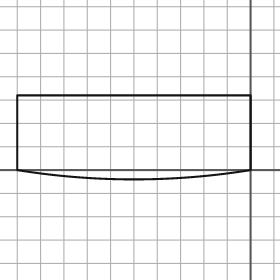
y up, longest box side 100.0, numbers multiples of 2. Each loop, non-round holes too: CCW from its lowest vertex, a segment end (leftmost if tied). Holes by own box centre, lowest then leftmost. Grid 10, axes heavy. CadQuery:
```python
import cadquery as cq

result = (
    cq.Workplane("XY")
    .moveTo(-100.0, 0.0)
    .threePointArc((-50.0, -4.0), (0.0, 0.0))
    .lineTo(0.0, 32.0)
    .lineTo(-100.0, 32.0)
    .close()
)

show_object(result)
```